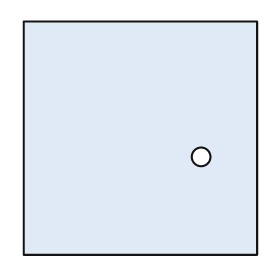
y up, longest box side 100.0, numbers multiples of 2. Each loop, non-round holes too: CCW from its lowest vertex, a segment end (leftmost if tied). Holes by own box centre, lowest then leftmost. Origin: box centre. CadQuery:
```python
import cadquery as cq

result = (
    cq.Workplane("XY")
    .moveTo(-50.0, -50.0)
    .lineTo(50.0, -50.0)
    .lineTo(50.0, 50.0)
    .lineTo(-50.0, 50.0)
    .close()
    .moveTo(26.0, -8.0)
    .circle(4.0)
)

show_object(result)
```